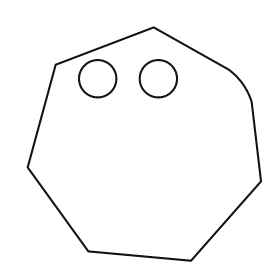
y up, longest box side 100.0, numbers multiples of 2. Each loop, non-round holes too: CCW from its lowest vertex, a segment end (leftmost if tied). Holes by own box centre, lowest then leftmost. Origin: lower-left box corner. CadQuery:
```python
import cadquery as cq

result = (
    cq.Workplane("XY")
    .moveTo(70.0, 0.0)
    .lineTo(100.0, 34.0)
    .lineTo(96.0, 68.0)
    .threePointArc((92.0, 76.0), (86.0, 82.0))
    .lineTo(54.0, 100.0)
    .lineTo(12.0, 84.0)
    .lineTo(0.0, 40.0)
    .lineTo(26.0, 4.0)
    .close()
    .moveTo(30.0, 78.0)
    .circle(8.0)
    .moveTo(56.0, 78.0)
    .circle(8.0)
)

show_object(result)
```